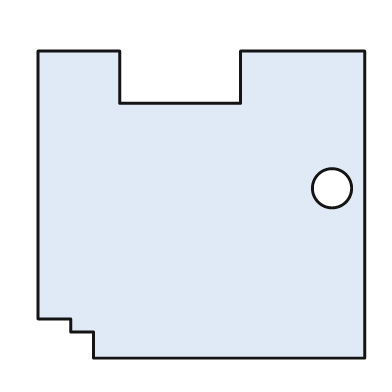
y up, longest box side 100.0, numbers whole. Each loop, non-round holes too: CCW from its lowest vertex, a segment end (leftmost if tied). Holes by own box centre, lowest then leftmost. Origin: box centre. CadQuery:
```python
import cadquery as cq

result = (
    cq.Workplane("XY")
    .moveTo(-33.0, -47.0)
    .lineTo(50.0, -47.0)
    .lineTo(50.0, 47.0)
    .lineTo(12.0, 47.0)
    .lineTo(12.0, 31.0)
    .lineTo(-25.0, 31.0)
    .lineTo(-25.0, 47.0)
    .lineTo(-50.0, 47.0)
    .lineTo(-50.0, -35.0)
    .lineTo(-40.0, -35.0)
    .lineTo(-40.0, -39.0)
    .lineTo(-33.0, -39.0)
    .close()
    .moveTo(40.0, 5.0)
    .circle(6.0)
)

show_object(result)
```